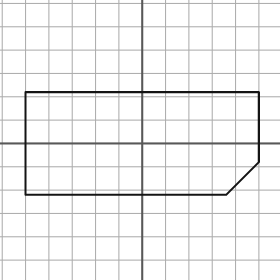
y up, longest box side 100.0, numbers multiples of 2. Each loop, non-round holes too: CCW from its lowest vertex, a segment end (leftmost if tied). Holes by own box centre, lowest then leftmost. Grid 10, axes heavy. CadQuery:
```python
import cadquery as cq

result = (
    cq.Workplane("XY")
    .moveTo(-50.0, -22.0)
    .lineTo(36.0, -22.0)
    .lineTo(50.0, -8.0)
    .lineTo(50.0, 22.0)
    .lineTo(-50.0, 22.0)
    .close()
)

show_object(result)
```